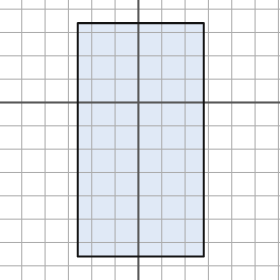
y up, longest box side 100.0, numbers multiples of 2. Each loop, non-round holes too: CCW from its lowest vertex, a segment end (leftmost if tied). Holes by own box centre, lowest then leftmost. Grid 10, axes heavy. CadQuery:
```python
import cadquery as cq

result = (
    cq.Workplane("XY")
    .moveTo(-26.0, -66.0)
    .lineTo(28.0, -66.0)
    .lineTo(28.0, 34.0)
    .lineTo(-26.0, 34.0)
    .close()
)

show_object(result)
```